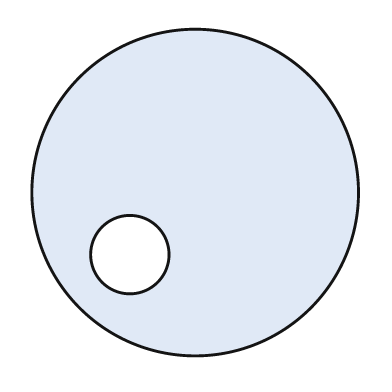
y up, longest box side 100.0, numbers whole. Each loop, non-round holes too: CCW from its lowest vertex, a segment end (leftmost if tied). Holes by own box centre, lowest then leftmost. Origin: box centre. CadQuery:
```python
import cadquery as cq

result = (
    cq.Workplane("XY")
    .moveTo(0.0, 0.0)
    .circle(50.0)
    .moveTo(-20.0, -19.0)
    .circle(12.0)
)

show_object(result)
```